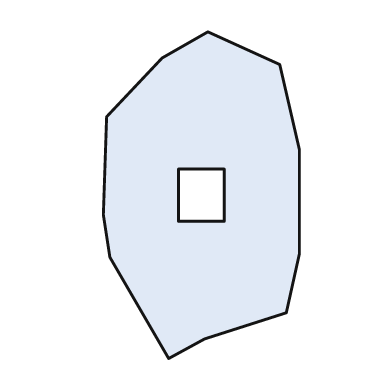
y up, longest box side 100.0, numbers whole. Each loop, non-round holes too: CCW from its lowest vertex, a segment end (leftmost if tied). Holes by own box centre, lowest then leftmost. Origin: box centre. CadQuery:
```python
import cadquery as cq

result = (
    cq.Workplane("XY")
    .moveTo(-10.0, -50.0)
    .lineTo(1.0, -44.0)
    .lineTo(26.0, -36.0)
    .lineTo(30.0, -18.0)
    .lineTo(30.0, 14.0)
    .lineTo(24.0, 40.0)
    .lineTo(2.0, 50.0)
    .lineTo(-12.0, 42.0)
    .lineTo(-29.0, 24.0)
    .lineTo(-30.0, -6.0)
    .lineTo(-28.0, -19.0)
    .close()
    .moveTo(-7.0, -8.0)
    .lineTo(7.0, -8.0)
    .lineTo(7.0, 8.0)
    .lineTo(-7.0, 8.0)
    .close()
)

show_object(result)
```